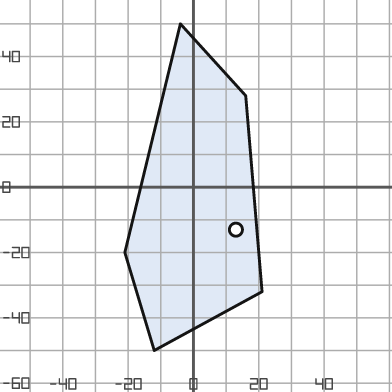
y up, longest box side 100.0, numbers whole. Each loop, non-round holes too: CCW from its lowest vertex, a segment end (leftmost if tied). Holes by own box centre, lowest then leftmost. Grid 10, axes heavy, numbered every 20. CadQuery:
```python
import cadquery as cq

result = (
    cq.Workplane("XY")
    .moveTo(-12.0, -50.0)
    .lineTo(21.0, -32.0)
    .lineTo(16.0, 28.0)
    .lineTo(-4.0, 50.0)
    .lineTo(-21.0, -20.0)
    .close()
    .moveTo(13.0, -13.0)
    .circle(2.0)
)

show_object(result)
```